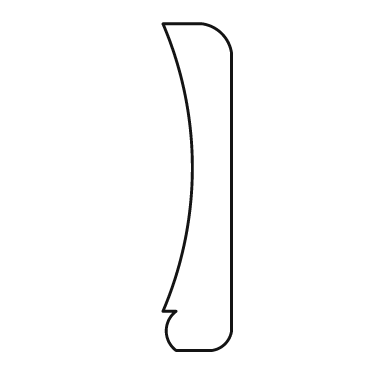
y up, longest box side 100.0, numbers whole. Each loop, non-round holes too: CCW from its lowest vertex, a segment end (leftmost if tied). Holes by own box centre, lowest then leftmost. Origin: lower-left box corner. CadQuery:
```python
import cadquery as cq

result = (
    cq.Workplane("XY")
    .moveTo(4.0, 0.0)
    .lineTo(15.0, 0.0)
    .threePointArc((19.0, 2.0), (21.0, 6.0))
    .lineTo(21.0, 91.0)
    .threePointArc((18.0, 97.0), (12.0, 100.0))
    .lineTo(0.0, 100.0)
    .threePointArc((9.0, 56.0), (0.0, 12.0))
    .lineTo(4.0, 12.0)
    .threePointArc((1.0, 6.0), (4.0, 0.0))
    .close()
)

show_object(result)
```